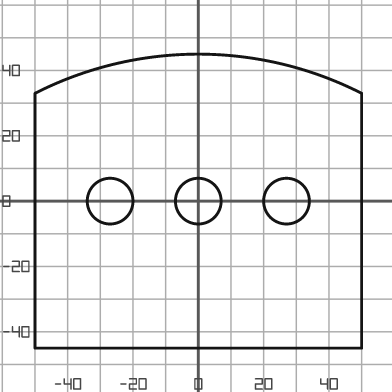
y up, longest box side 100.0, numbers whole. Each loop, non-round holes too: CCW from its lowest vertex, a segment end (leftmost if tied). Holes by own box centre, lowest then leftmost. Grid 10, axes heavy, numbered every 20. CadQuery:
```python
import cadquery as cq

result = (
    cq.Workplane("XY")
    .moveTo(-50.0, -45.0)
    .lineTo(50.0, -45.0)
    .lineTo(50.0, 33.0)
    .threePointArc((0.0, 45.0), (-50.0, 33.0))
    .close()
    .moveTo(-27.0, 0.0)
    .circle(7.0)
    .moveTo(0.0, 0.0)
    .circle(7.0)
    .moveTo(27.0, 0.0)
    .circle(7.0)
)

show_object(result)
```